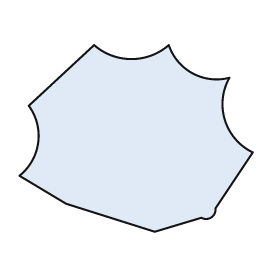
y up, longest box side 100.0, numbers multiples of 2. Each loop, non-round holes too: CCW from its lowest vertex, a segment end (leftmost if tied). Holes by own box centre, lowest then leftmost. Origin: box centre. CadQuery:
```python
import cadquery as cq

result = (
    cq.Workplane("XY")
    .moveTo(8.0, -40.0)
    .lineTo(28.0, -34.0)
    .threePointArc((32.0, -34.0), (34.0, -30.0))
    .lineTo(50.0, -6.0)
    .threePointArc((38.0, 8.0), (40.0, 26.0))
    .threePointArc((24.0, 28.0), (14.0, 40.0))
    .threePointArc((-2.0, 34.0), (-18.0, 40.0))
    .lineTo(-46.0, 14.0)
    .threePointArc((-42.0, -2.0), (-50.0, -16.0))
    .lineTo(-30.0, -28.0)
    .close()
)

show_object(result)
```